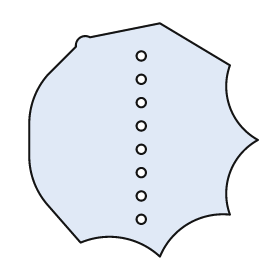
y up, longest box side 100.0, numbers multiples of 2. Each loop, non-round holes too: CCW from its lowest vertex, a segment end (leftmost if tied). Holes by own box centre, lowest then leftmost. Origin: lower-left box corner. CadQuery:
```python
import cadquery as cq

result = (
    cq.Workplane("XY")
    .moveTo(56.0, 0.0)
    .threePointArc((68.0, 14.0), (86.0, 18.0))
    .threePointArc((86.0, 36.0), (98.0, 50.0))
    .threePointArc((86.0, 64.0), (86.0, 82.0))
    .lineTo(56.0, 100.0)
    .lineTo(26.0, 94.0)
    .threePointArc((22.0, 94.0), (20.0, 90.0))
    .lineTo(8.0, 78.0)
    .threePointArc((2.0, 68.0), (0.0, 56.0))
    .lineTo(0.0, 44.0)
    .threePointArc((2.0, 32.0), (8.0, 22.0))
    .lineTo(22.0, 6.0)
    .threePointArc((40.0, 8.0), (56.0, 0.0))
    .close()
    .moveTo(48.0, 16.0)
    .circle(2.0)
    .moveTo(48.0, 26.0)
    .circle(2.0)
    .moveTo(48.0, 36.0)
    .circle(2.0)
    .moveTo(48.0, 46.0)
    .circle(2.0)
    .moveTo(48.0, 56.0)
    .circle(2.0)
    .moveTo(48.0, 66.0)
    .circle(2.0)
    .moveTo(48.0, 76.0)
    .circle(2.0)
    .moveTo(48.0, 86.0)
    .circle(2.0)
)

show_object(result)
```